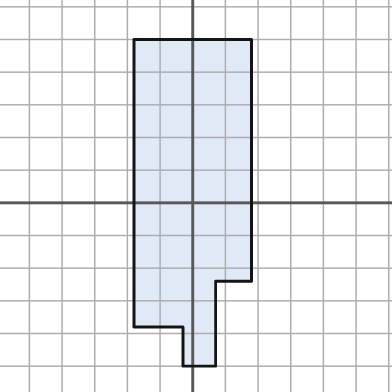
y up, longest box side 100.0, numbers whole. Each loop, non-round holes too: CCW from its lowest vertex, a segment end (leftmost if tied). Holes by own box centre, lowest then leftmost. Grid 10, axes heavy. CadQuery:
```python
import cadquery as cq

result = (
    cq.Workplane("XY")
    .moveTo(-3.0, -50.0)
    .lineTo(7.0, -50.0)
    .lineTo(7.0, -24.0)
    .lineTo(18.0, -24.0)
    .lineTo(18.0, 50.0)
    .lineTo(-18.0, 50.0)
    .lineTo(-18.0, -38.0)
    .lineTo(-3.0, -38.0)
    .close()
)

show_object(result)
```